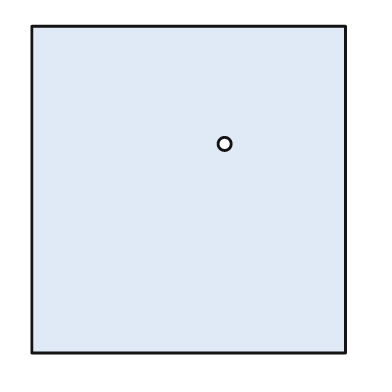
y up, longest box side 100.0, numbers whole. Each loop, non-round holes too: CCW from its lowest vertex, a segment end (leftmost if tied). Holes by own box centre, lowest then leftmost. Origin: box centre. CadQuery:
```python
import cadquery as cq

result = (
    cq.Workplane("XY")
    .moveTo(-48.0, -50.0)
    .lineTo(48.0, -50.0)
    .lineTo(48.0, 50.0)
    .lineTo(-48.0, 50.0)
    .close()
    .moveTo(11.0, 14.0)
    .circle(2.0)
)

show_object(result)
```